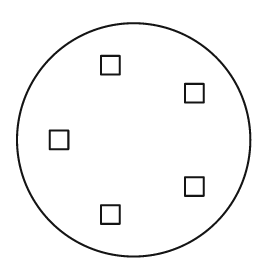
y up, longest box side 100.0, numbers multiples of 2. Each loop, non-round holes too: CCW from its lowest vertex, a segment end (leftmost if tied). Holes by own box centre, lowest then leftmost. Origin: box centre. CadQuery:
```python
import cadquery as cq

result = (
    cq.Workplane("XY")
    .moveTo(0.0, 0.0)
    .circle(50.0)
    .moveTo(-14.0, -36.0)
    .lineTo(-6.0, -36.0)
    .lineTo(-6.0, -28.0)
    .lineTo(-14.0, -28.0)
    .close()
    .moveTo(22.0, -24.0)
    .lineTo(30.0, -24.0)
    .lineTo(30.0, -16.0)
    .lineTo(22.0, -16.0)
    .close()
    .moveTo(-36.0, -4.0)
    .lineTo(-28.0, -4.0)
    .lineTo(-28.0, 4.0)
    .lineTo(-36.0, 4.0)
    .close()
    .moveTo(22.0, 16.0)
    .lineTo(30.0, 16.0)
    .lineTo(30.0, 24.0)
    .lineTo(22.0, 24.0)
    .close()
    .moveTo(-14.0, 28.0)
    .lineTo(-6.0, 28.0)
    .lineTo(-6.0, 36.0)
    .lineTo(-14.0, 36.0)
    .close()
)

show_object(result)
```